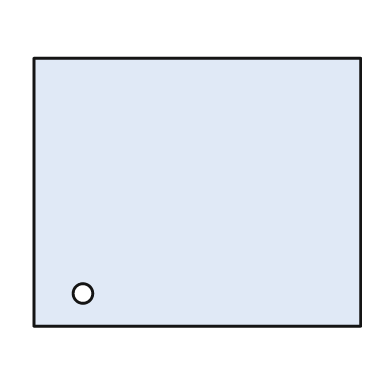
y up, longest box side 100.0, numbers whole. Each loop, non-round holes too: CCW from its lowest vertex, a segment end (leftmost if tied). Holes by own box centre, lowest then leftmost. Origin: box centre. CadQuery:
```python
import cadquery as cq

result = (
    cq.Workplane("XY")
    .moveTo(-50.0, -41.0)
    .lineTo(50.0, -41.0)
    .lineTo(50.0, 41.0)
    .lineTo(-50.0, 41.0)
    .close()
    .moveTo(-35.0, -31.0)
    .circle(3.0)
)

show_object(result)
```